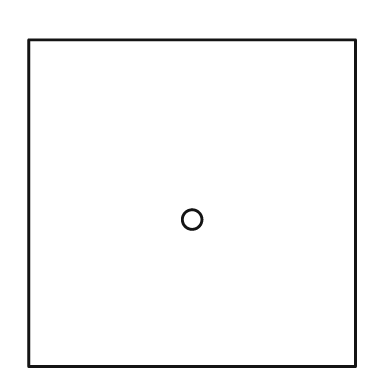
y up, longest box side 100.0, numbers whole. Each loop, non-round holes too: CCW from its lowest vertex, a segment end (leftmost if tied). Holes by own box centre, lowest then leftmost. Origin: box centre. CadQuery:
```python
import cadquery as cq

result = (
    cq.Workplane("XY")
    .moveTo(-50.0, -50.0)
    .lineTo(50.0, -50.0)
    .lineTo(50.0, 50.0)
    .lineTo(-50.0, 50.0)
    .close()
    .moveTo(0.0, -5.0)
    .circle(3.0)
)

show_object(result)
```